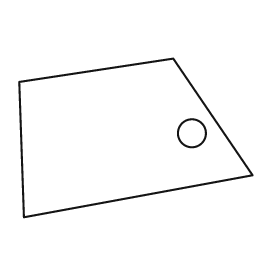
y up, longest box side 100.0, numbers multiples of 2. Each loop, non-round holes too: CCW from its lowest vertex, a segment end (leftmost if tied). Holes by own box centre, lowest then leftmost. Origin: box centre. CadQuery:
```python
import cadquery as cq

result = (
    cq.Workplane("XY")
    .moveTo(-48.0, -34.0)
    .lineTo(50.0, -16.0)
    .lineTo(16.0, 34.0)
    .lineTo(-50.0, 24.0)
    .close()
    .moveTo(24.0, 2.0)
    .circle(6.0)
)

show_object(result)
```